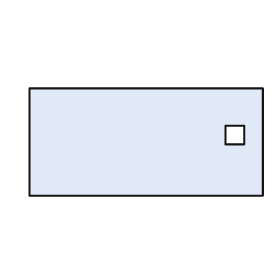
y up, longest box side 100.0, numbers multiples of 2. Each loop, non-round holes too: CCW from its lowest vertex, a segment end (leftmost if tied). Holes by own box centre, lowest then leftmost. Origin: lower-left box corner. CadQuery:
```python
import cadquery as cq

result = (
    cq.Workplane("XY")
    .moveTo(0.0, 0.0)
    .lineTo(100.0, 0.0)
    .lineTo(100.0, 46.0)
    .lineTo(0.0, 46.0)
    .close()
    .moveTo(84.0, 22.0)
    .lineTo(92.0, 22.0)
    .lineTo(92.0, 30.0)
    .lineTo(84.0, 30.0)
    .close()
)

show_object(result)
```